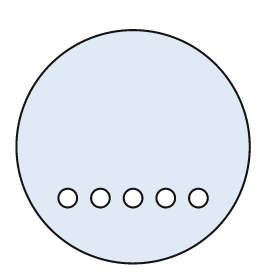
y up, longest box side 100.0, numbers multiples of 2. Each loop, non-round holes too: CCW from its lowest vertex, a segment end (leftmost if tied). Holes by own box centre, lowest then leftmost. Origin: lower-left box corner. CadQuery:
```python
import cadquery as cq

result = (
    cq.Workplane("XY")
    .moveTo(50.0, 50.0)
    .circle(50.0)
    .moveTo(22.0, 28.0)
    .circle(4.0)
    .moveTo(36.0, 28.0)
    .circle(4.0)
    .moveTo(50.0, 28.0)
    .circle(4.0)
    .moveTo(64.0, 28.0)
    .circle(4.0)
    .moveTo(78.0, 28.0)
    .circle(4.0)
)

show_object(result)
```